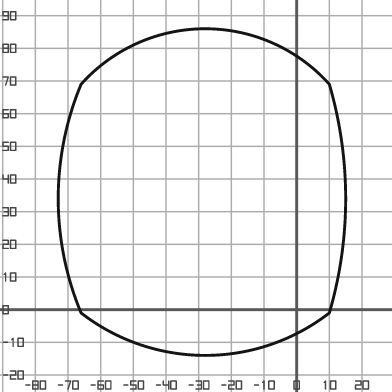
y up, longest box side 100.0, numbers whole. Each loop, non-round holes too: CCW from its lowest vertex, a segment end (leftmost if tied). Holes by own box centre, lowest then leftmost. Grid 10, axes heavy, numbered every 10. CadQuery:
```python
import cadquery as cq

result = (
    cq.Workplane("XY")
    .moveTo(-66.0, -1.0)
    .threePointArc((-28.0, -14.0), (10.0, -1.0))
    .threePointArc((15.0, 34.0), (10.0, 69.0))
    .threePointArc((-28.0, 86.0), (-66.0, 69.0))
    .threePointArc((-73.0, 34.0), (-66.0, -1.0))
    .close()
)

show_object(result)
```